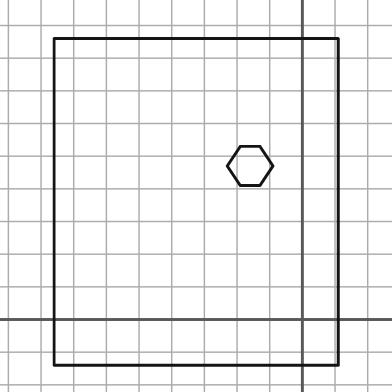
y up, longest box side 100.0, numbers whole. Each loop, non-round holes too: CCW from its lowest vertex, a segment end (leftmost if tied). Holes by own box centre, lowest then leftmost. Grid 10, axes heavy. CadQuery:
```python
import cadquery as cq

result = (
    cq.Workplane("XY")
    .moveTo(-76.0, -14.0)
    .lineTo(11.0, -14.0)
    .lineTo(11.0, 86.0)
    .lineTo(-76.0, 86.0)
    .close()
    .moveTo(-19.0, 41.0)
    .lineTo(-13.0, 41.0)
    .lineTo(-9.0, 47.0)
    .lineTo(-13.0, 53.0)
    .lineTo(-19.0, 53.0)
    .lineTo(-23.0, 47.0)
    .close()
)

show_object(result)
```